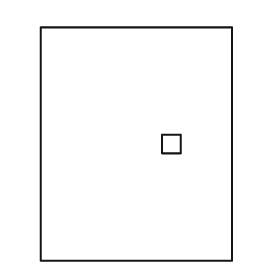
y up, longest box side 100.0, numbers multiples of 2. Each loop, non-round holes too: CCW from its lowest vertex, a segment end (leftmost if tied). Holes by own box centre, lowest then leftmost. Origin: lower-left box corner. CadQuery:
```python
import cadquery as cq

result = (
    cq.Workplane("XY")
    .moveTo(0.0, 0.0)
    .lineTo(82.0, 0.0)
    .lineTo(82.0, 100.0)
    .lineTo(0.0, 100.0)
    .close()
    .moveTo(52.0, 46.0)
    .lineTo(60.0, 46.0)
    .lineTo(60.0, 54.0)
    .lineTo(52.0, 54.0)
    .close()
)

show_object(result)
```